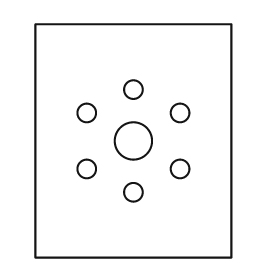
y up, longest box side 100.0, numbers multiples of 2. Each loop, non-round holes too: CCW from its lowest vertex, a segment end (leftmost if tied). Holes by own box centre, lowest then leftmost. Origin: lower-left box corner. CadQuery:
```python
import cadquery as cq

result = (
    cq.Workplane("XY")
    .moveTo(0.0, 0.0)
    .lineTo(84.0, 0.0)
    .lineTo(84.0, 100.0)
    .lineTo(0.0, 100.0)
    .close()
    .moveTo(42.0, 28.0)
    .circle(4.0)
    .moveTo(22.0, 38.0)
    .circle(4.0)
    .moveTo(62.0, 38.0)
    .circle(4.0)
    .moveTo(42.0, 50.0)
    .circle(8.0)
    .moveTo(22.0, 62.0)
    .circle(4.0)
    .moveTo(62.0, 62.0)
    .circle(4.0)
    .moveTo(42.0, 72.0)
    .circle(4.0)
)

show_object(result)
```